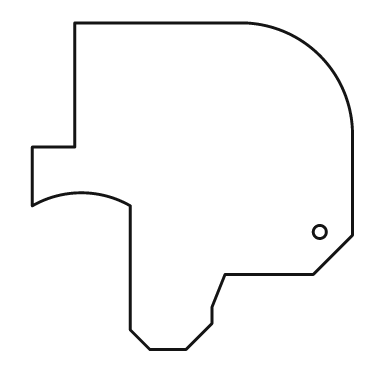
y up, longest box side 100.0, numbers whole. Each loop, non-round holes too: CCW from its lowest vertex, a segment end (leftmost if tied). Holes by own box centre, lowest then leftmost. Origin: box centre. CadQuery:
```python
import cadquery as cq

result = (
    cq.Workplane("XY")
    .moveTo(-13.0, -50.0)
    .lineTo(-2.0, -50.0)
    .lineTo(6.0, -42.0)
    .lineTo(6.0, -37.0)
    .lineTo(10.0, -27.0)
    .lineTo(37.0, -27.0)
    .lineTo(49.0, -15.0)
    .lineTo(49.0, 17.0)
    .threePointArc((39.0, 40.0), (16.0, 50.0))
    .lineTo(-36.0, 50.0)
    .lineTo(-36.0, 12.0)
    .lineTo(-49.0, 12.0)
    .lineTo(-49.0, -6.0)
    .threePointArc((-34.0, -2.0), (-19.0, -6.0))
    .lineTo(-19.0, -44.0)
    .close()
    .moveTo(39.0, -14.0)
    .circle(2.0)
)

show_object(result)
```